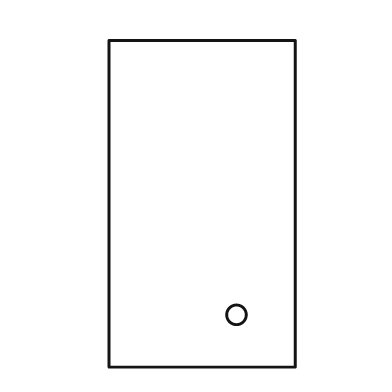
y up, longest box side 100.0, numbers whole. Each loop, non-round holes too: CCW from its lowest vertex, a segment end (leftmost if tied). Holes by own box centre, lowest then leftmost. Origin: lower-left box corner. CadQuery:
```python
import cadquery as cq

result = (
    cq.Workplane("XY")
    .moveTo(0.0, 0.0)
    .lineTo(57.0, 0.0)
    .lineTo(57.0, 100.0)
    .lineTo(0.0, 100.0)
    .close()
    .moveTo(39.0, 16.0)
    .circle(3.0)
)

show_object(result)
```